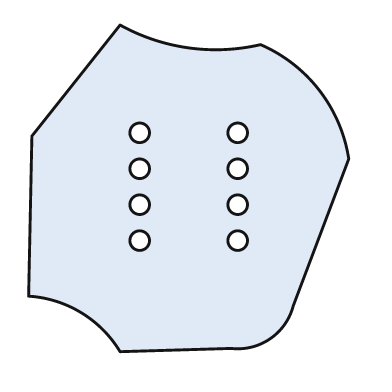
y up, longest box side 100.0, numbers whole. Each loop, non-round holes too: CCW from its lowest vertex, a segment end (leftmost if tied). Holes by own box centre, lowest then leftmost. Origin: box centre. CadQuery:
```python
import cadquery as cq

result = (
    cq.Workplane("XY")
    .moveTo(-21.0, -50.0)
    .lineTo(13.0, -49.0)
    .threePointArc((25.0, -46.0), (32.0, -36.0))
    .lineTo(49.0, 9.0)
    .threePointArc((40.0, 30.0), (22.0, 44.0))
    .threePointArc((0.0, 43.0), (-21.0, 50.0))
    .lineTo(-48.0, 16.0)
    .lineTo(-49.0, -33.0)
    .threePointArc((-33.0, -38.0), (-21.0, -50.0))
    .close()
    .moveTo(-15.0, -16.0)
    .circle(3.0)
    .moveTo(15.0, -16.0)
    .circle(3.0)
    .moveTo(-15.0, -5.0)
    .circle(3.0)
    .moveTo(15.0, -5.0)
    .circle(3.0)
    .moveTo(-15.0, 6.0)
    .circle(3.0)
    .moveTo(15.0, 6.0)
    .circle(3.0)
    .moveTo(-15.0, 17.0)
    .circle(3.0)
    .moveTo(15.0, 17.0)
    .circle(3.0)
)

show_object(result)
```